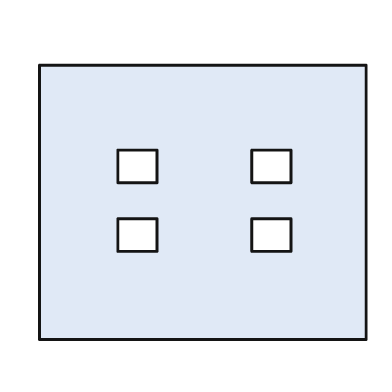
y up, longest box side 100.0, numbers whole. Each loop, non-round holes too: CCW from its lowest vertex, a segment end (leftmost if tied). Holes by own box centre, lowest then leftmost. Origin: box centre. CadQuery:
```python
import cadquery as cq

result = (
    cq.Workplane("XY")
    .moveTo(-50.0, -42.0)
    .lineTo(50.0, -42.0)
    .lineTo(50.0, 42.0)
    .lineTo(-50.0, 42.0)
    .close()
    .moveTo(-26.0, -15.0)
    .lineTo(-14.0, -15.0)
    .lineTo(-14.0, -5.0)
    .lineTo(-26.0, -5.0)
    .close()
    .moveTo(15.0, -15.0)
    .lineTo(27.0, -15.0)
    .lineTo(27.0, -5.0)
    .lineTo(15.0, -5.0)
    .close()
    .moveTo(-26.0, 6.0)
    .lineTo(-14.0, 6.0)
    .lineTo(-14.0, 16.0)
    .lineTo(-26.0, 16.0)
    .close()
    .moveTo(15.0, 6.0)
    .lineTo(27.0, 6.0)
    .lineTo(27.0, 16.0)
    .lineTo(15.0, 16.0)
    .close()
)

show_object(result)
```